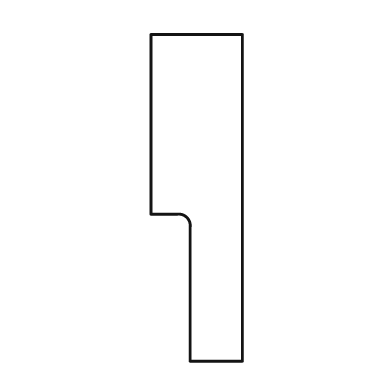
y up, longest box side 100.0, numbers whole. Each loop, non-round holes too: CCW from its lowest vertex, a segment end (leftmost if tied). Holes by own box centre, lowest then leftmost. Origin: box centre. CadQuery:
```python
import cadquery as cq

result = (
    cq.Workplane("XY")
    .moveTo(-2.0, -50.0)
    .lineTo(14.0, -50.0)
    .lineTo(14.0, 50.0)
    .lineTo(-14.0, 50.0)
    .lineTo(-14.0, -5.0)
    .lineTo(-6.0, -5.0)
    .threePointArc((-3.0, -6.0), (-2.0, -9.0))
    .close()
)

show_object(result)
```